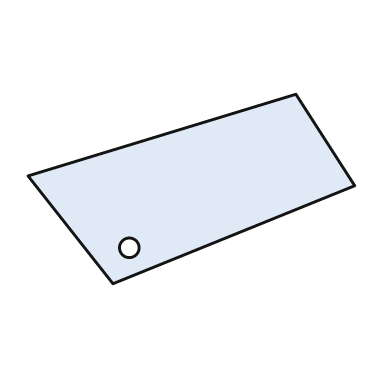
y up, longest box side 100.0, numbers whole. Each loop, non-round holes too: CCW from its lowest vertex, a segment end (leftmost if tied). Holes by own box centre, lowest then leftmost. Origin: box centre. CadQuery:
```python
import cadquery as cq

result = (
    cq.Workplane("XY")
    .moveTo(-24.0, -29.0)
    .lineTo(50.0, 1.0)
    .lineTo(32.0, 29.0)
    .lineTo(-50.0, 4.0)
    .close()
    .moveTo(-19.0, -18.0)
    .circle(3.0)
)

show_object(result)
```